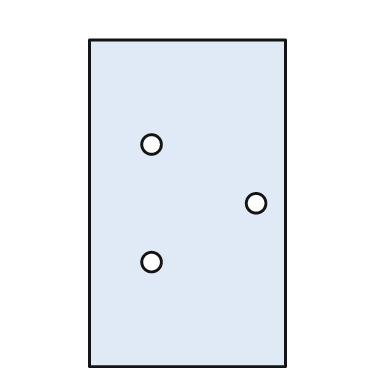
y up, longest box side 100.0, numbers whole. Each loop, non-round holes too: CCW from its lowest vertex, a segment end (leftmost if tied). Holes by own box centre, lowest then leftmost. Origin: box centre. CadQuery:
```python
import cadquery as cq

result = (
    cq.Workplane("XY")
    .moveTo(-30.0, -50.0)
    .lineTo(30.0, -50.0)
    .lineTo(30.0, 50.0)
    .lineTo(-30.0, 50.0)
    .close()
    .moveTo(-11.0, -18.0)
    .circle(3.0)
    .moveTo(21.0, 0.0)
    .circle(3.0)
    .moveTo(-11.0, 18.0)
    .circle(3.0)
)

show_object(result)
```